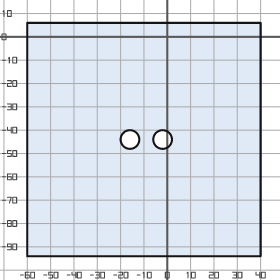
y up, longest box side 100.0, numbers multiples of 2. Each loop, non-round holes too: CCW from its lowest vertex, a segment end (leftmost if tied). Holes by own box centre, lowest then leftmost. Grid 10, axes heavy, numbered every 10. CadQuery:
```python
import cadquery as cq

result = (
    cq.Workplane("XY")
    .moveTo(-60.0, -94.0)
    .lineTo(40.0, -94.0)
    .lineTo(40.0, 6.0)
    .lineTo(-60.0, 6.0)
    .close()
    .moveTo(-16.0, -44.0)
    .circle(4.0)
    .moveTo(-2.0, -44.0)
    .circle(4.0)
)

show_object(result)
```